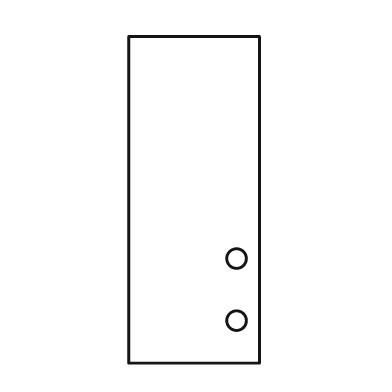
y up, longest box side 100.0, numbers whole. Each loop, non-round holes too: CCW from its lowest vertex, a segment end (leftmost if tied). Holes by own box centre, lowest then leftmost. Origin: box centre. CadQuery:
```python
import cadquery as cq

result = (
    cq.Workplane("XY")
    .moveTo(-20.0, -50.0)
    .lineTo(20.0, -50.0)
    .lineTo(20.0, 50.0)
    .lineTo(-20.0, 50.0)
    .close()
    .moveTo(13.0, -37.0)
    .circle(3.0)
    .moveTo(13.0, -18.0)
    .circle(3.0)
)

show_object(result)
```